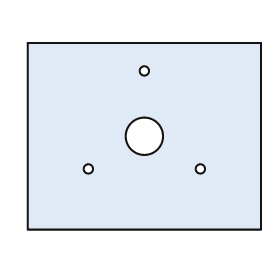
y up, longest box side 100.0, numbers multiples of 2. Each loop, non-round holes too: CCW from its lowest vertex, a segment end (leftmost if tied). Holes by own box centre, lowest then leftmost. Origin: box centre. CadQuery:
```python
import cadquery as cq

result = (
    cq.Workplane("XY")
    .moveTo(-50.0, -40.0)
    .lineTo(50.0, -40.0)
    .lineTo(50.0, 40.0)
    .lineTo(-50.0, 40.0)
    .close()
    .moveTo(-24.0, -14.0)
    .circle(2.0)
    .moveTo(24.0, -14.0)
    .circle(2.0)
    .moveTo(0.0, 0.0)
    .circle(8.0)
    .moveTo(0.0, 28.0)
    .circle(2.0)
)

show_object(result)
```